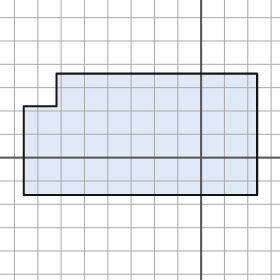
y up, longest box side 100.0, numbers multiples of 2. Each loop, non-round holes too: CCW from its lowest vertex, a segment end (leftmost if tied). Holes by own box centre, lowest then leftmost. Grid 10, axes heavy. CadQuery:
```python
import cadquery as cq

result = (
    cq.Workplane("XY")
    .moveTo(-76.0, -16.0)
    .lineTo(24.0, -16.0)
    .lineTo(24.0, 36.0)
    .lineTo(-62.0, 36.0)
    .lineTo(-62.0, 22.0)
    .lineTo(-76.0, 22.0)
    .close()
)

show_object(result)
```